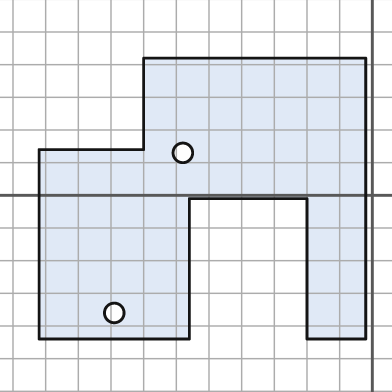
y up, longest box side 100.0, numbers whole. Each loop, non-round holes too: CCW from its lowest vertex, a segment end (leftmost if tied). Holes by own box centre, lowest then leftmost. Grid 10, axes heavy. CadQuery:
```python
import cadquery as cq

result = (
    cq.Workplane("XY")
    .moveTo(-102.0, -44.0)
    .lineTo(-56.0, -44.0)
    .lineTo(-56.0, -1.0)
    .lineTo(-20.0, -1.0)
    .lineTo(-20.0, -44.0)
    .lineTo(-2.0, -44.0)
    .lineTo(-2.0, 42.0)
    .lineTo(-70.0, 42.0)
    .lineTo(-70.0, 14.0)
    .lineTo(-102.0, 14.0)
    .close()
    .moveTo(-79.0, -36.0)
    .circle(3.0)
    .moveTo(-58.0, 13.0)
    .circle(3.0)
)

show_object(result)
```